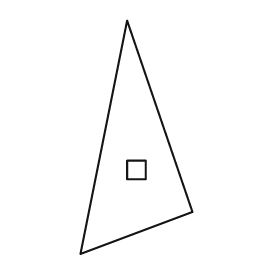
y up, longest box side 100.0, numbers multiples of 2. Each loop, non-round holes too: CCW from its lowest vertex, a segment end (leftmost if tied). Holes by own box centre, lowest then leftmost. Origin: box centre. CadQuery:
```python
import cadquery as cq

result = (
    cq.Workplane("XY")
    .moveTo(-24.0, -50.0)
    .lineTo(24.0, -32.0)
    .lineTo(-4.0, 50.0)
    .close()
    .moveTo(-4.0, -18.0)
    .lineTo(4.0, -18.0)
    .lineTo(4.0, -10.0)
    .lineTo(-4.0, -10.0)
    .close()
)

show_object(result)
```